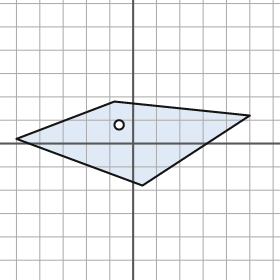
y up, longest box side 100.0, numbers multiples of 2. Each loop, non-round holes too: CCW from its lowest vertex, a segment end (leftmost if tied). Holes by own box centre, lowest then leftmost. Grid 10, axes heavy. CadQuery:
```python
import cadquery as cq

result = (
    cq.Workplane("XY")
    .moveTo(4.0, -18.0)
    .lineTo(50.0, 12.0)
    .lineTo(-8.0, 18.0)
    .lineTo(-50.0, 2.0)
    .close()
    .moveTo(-6.0, 8.0)
    .circle(2.0)
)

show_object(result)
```